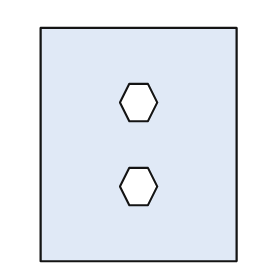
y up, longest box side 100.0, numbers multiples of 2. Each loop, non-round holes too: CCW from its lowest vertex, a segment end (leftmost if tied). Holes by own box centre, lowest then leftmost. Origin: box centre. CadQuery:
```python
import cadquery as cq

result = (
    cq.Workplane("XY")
    .moveTo(-42.0, -50.0)
    .lineTo(42.0, -50.0)
    .lineTo(42.0, 50.0)
    .lineTo(-42.0, 50.0)
    .close()
    .moveTo(-4.0, -26.0)
    .lineTo(4.0, -26.0)
    .lineTo(8.0, -18.0)
    .lineTo(4.0, -10.0)
    .lineTo(-4.0, -10.0)
    .lineTo(-8.0, -18.0)
    .close()
    .moveTo(-4.0, 10.0)
    .lineTo(4.0, 10.0)
    .lineTo(8.0, 18.0)
    .lineTo(4.0, 26.0)
    .lineTo(-4.0, 26.0)
    .lineTo(-8.0, 18.0)
    .close()
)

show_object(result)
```